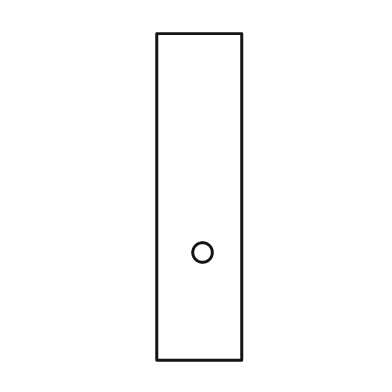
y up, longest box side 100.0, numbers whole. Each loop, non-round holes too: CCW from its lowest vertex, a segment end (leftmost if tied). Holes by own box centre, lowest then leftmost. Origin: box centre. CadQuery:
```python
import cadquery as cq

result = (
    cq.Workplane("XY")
    .moveTo(-13.0, -50.0)
    .lineTo(13.0, -50.0)
    .lineTo(13.0, 50.0)
    .lineTo(-13.0, 50.0)
    .close()
    .moveTo(1.0, -17.0)
    .circle(3.0)
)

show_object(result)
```